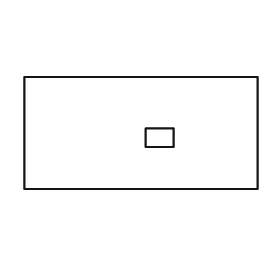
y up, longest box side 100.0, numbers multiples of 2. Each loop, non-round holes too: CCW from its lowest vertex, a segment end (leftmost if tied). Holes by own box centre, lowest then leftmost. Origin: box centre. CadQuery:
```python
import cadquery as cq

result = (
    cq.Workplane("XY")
    .moveTo(-50.0, -24.0)
    .lineTo(50.0, -24.0)
    .lineTo(50.0, 24.0)
    .lineTo(-50.0, 24.0)
    .close()
    .moveTo(2.0, -6.0)
    .lineTo(14.0, -6.0)
    .lineTo(14.0, 2.0)
    .lineTo(2.0, 2.0)
    .close()
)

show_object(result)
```